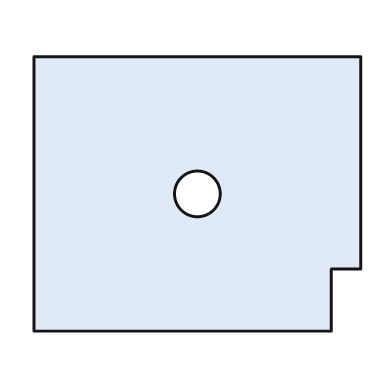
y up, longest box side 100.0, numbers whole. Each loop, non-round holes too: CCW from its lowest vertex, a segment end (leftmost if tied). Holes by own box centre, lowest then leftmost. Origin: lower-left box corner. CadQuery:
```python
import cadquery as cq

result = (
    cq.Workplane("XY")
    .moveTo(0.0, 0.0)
    .lineTo(91.0, 0.0)
    .lineTo(91.0, 19.0)
    .lineTo(100.0, 19.0)
    .lineTo(100.0, 84.0)
    .lineTo(0.0, 84.0)
    .close()
    .moveTo(50.0, 42.0)
    .circle(7.0)
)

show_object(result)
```